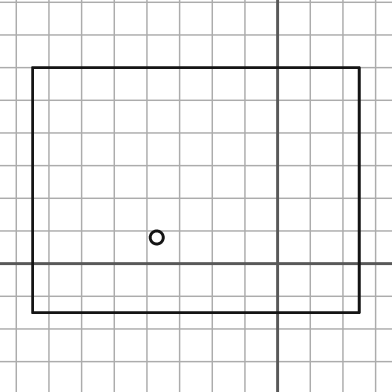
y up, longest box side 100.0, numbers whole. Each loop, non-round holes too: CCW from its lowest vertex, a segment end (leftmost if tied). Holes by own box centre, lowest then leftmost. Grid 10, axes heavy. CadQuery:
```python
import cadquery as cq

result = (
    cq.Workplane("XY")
    .moveTo(-75.0, -15.0)
    .lineTo(25.0, -15.0)
    .lineTo(25.0, 60.0)
    .lineTo(-75.0, 60.0)
    .close()
    .moveTo(-37.0, 8.0)
    .circle(2.0)
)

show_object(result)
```